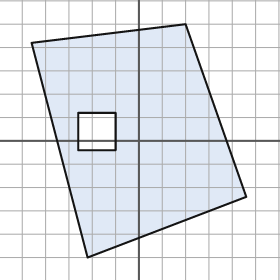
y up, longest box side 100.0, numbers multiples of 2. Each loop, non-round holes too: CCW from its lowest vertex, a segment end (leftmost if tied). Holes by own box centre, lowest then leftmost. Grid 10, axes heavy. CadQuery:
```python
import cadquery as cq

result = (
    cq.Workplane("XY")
    .moveTo(-22.0, -50.0)
    .lineTo(46.0, -24.0)
    .lineTo(20.0, 50.0)
    .lineTo(-46.0, 42.0)
    .close()
    .moveTo(-26.0, -4.0)
    .lineTo(-10.0, -4.0)
    .lineTo(-10.0, 12.0)
    .lineTo(-26.0, 12.0)
    .close()
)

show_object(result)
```